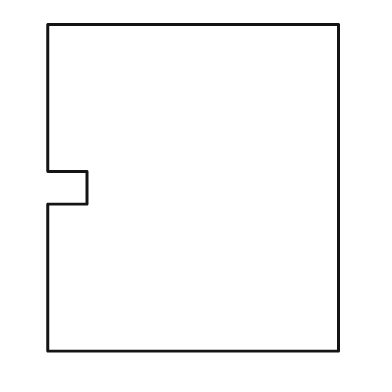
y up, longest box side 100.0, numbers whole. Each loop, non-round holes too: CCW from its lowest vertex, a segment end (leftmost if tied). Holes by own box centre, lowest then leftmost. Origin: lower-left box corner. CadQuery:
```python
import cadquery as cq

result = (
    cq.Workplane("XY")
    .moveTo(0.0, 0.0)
    .lineTo(89.0, 0.0)
    .lineTo(89.0, 100.0)
    .lineTo(0.0, 100.0)
    .lineTo(0.0, 55.0)
    .lineTo(12.0, 55.0)
    .lineTo(12.0, 45.0)
    .lineTo(0.0, 45.0)
    .close()
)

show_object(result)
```